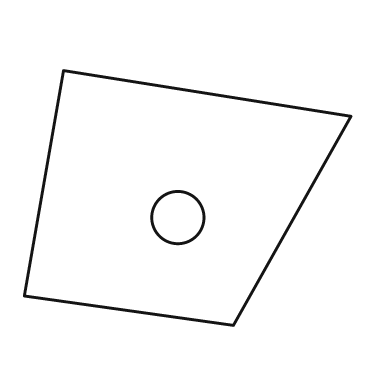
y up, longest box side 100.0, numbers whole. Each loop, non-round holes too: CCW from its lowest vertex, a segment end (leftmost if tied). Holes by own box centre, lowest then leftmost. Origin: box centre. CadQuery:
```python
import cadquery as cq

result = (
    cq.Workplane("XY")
    .moveTo(14.0, -39.0)
    .lineTo(50.0, 25.0)
    .lineTo(-38.0, 39.0)
    .lineTo(-50.0, -30.0)
    .close()
    .moveTo(-3.0, -6.0)
    .circle(8.0)
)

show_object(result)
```